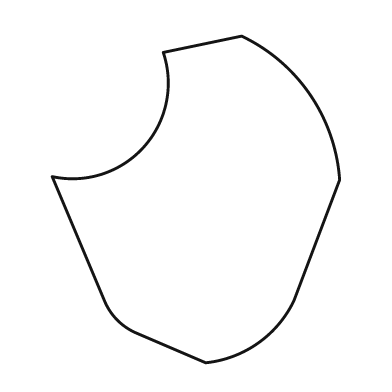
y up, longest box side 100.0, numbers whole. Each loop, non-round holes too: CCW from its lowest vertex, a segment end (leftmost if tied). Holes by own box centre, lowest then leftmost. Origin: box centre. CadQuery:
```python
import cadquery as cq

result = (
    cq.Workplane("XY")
    .moveTo(3.0, -50.0)
    .threePointArc((19.0, -44.0), (30.0, -31.0))
    .lineTo(44.0, 6.0)
    .threePointArc((35.0, 32.0), (14.0, 50.0))
    .lineTo(-10.0, 45.0)
    .threePointArc((-16.0, 16.0), (-44.0, 7.0))
    .lineTo(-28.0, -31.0)
    .threePointArc((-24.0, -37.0), (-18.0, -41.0))
    .close()
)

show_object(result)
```